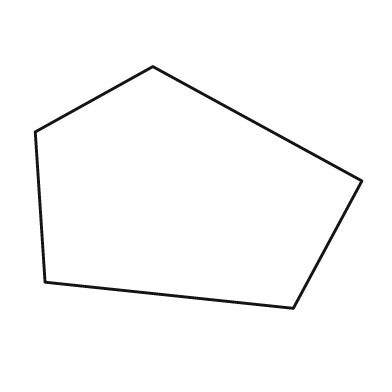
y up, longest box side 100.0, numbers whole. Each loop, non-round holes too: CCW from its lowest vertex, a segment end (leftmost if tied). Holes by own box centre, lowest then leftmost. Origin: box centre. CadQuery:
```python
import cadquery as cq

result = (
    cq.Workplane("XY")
    .moveTo(29.0, -37.0)
    .lineTo(50.0, 2.0)
    .lineTo(-14.0, 37.0)
    .lineTo(-50.0, 17.0)
    .lineTo(-47.0, -29.0)
    .close()
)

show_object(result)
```